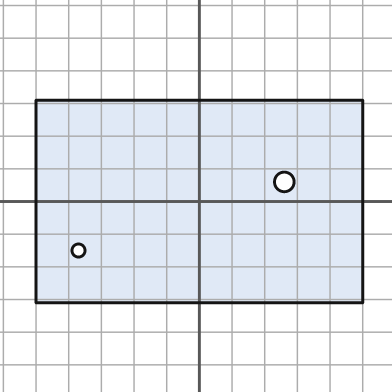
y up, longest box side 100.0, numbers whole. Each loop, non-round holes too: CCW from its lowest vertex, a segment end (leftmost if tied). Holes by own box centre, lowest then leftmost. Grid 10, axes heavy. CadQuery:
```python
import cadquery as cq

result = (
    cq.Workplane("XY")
    .moveTo(-50.0, -31.0)
    .lineTo(50.0, -31.0)
    .lineTo(50.0, 31.0)
    .lineTo(-50.0, 31.0)
    .close()
    .moveTo(-37.0, -15.0)
    .circle(2.0)
    .moveTo(26.0, 6.0)
    .circle(3.0)
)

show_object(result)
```